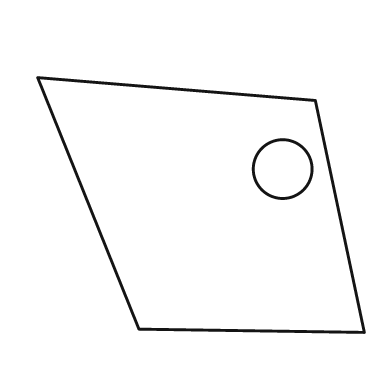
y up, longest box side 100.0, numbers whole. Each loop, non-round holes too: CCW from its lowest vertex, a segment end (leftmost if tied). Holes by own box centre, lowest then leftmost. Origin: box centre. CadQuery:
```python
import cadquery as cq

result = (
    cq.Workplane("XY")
    .moveTo(50.0, -39.0)
    .lineTo(35.0, 32.0)
    .lineTo(-50.0, 39.0)
    .lineTo(-19.0, -38.0)
    .close()
    .moveTo(25.0, 11.0)
    .circle(9.0)
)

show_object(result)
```